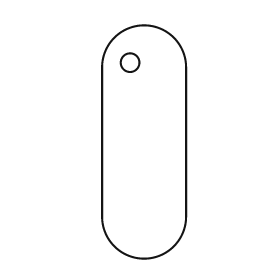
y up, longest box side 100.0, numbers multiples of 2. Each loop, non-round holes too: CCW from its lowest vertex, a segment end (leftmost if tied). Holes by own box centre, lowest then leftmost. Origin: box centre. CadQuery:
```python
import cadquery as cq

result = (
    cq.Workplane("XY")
    .moveTo(-18.0, -32.0)
    .threePointArc((0.0, -50.0), (18.0, -32.0))
    .lineTo(18.0, 32.0)
    .threePointArc((0.0, 50.0), (-18.0, 32.0))
    .close()
    .moveTo(-6.0, 34.0)
    .circle(4.0)
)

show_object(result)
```